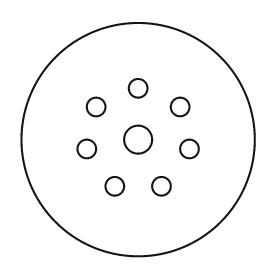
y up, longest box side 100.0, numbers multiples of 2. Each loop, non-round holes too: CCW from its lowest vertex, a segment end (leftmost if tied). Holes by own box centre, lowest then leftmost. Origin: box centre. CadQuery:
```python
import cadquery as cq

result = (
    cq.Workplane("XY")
    .moveTo(0.0, 0.0)
    .circle(50.0)
    .moveTo(-10.0, -20.0)
    .circle(4.0)
    .moveTo(10.0, -20.0)
    .circle(4.0)
    .moveTo(-22.0, -4.0)
    .circle(4.0)
    .moveTo(22.0, -4.0)
    .circle(4.0)
    .moveTo(0.0, 0.0)
    .circle(6.0)
    .moveTo(-18.0, 14.0)
    .circle(4.0)
    .moveTo(18.0, 14.0)
    .circle(4.0)
    .moveTo(0.0, 22.0)
    .circle(4.0)
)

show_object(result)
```